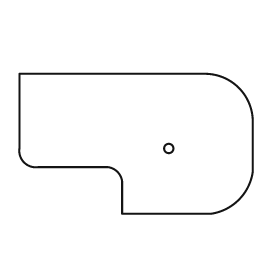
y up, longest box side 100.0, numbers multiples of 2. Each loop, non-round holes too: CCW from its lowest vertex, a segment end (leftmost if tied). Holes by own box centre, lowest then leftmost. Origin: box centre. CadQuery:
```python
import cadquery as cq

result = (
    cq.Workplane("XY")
    .moveTo(-6.0, -30.0)
    .lineTo(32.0, -30.0)
    .threePointArc((44.0, -24.0), (50.0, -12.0))
    .lineTo(50.0, 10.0)
    .threePointArc((44.0, 24.0), (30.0, 30.0))
    .lineTo(-50.0, 30.0)
    .lineTo(-50.0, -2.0)
    .threePointArc((-48.0, -8.0), (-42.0, -10.0))
    .lineTo(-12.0, -10.0)
    .threePointArc((-8.0, -12.0), (-6.0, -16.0))
    .close()
    .moveTo(14.0, -2.0)
    .circle(2.0)
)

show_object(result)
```